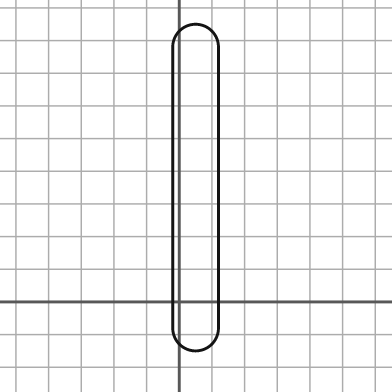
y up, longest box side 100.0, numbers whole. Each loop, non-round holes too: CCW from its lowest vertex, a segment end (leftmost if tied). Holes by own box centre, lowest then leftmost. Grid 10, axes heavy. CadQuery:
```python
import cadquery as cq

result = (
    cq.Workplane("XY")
    .moveTo(-2.0, -8.0)
    .threePointArc((5.0, -15.0), (12.0, -8.0))
    .lineTo(12.0, 78.0)
    .threePointArc((5.0, 85.0), (-2.0, 78.0))
    .close()
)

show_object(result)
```